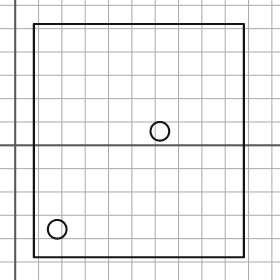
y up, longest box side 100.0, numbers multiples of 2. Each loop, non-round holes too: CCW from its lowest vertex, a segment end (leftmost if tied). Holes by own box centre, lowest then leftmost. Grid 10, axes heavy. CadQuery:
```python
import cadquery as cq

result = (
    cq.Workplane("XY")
    .moveTo(8.0, -48.0)
    .lineTo(98.0, -48.0)
    .lineTo(98.0, 52.0)
    .lineTo(8.0, 52.0)
    .close()
    .moveTo(18.0, -36.0)
    .circle(4.0)
    .moveTo(62.0, 6.0)
    .circle(4.0)
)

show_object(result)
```